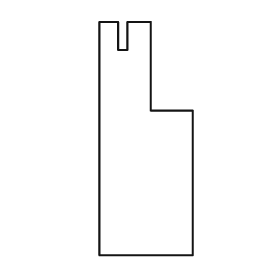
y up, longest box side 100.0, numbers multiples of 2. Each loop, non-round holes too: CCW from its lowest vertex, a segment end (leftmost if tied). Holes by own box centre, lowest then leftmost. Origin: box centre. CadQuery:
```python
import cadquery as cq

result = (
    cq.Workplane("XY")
    .moveTo(-20.0, -50.0)
    .lineTo(20.0, -50.0)
    .lineTo(20.0, 12.0)
    .lineTo(2.0, 12.0)
    .lineTo(2.0, 50.0)
    .lineTo(-8.0, 50.0)
    .lineTo(-8.0, 38.0)
    .lineTo(-12.0, 38.0)
    .lineTo(-12.0, 50.0)
    .lineTo(-20.0, 50.0)
    .close()
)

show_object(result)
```